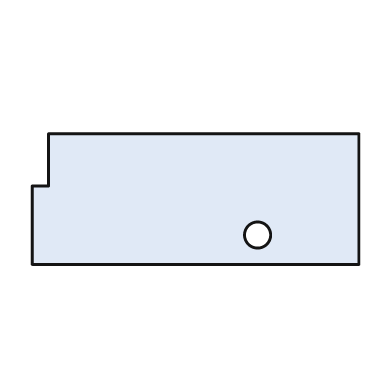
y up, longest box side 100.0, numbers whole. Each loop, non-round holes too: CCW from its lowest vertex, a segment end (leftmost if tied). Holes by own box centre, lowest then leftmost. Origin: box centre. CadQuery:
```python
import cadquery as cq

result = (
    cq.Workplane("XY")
    .moveTo(-50.0, -20.0)
    .lineTo(50.0, -20.0)
    .lineTo(50.0, 20.0)
    .lineTo(-45.0, 20.0)
    .lineTo(-45.0, 4.0)
    .lineTo(-50.0, 4.0)
    .close()
    .moveTo(19.0, -11.0)
    .circle(4.0)
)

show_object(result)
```